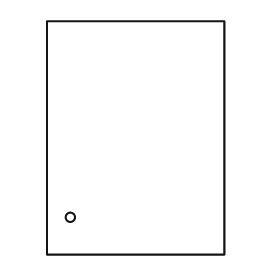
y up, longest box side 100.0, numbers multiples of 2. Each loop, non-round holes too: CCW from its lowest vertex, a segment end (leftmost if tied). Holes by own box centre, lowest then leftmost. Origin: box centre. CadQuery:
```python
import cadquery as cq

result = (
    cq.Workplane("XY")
    .moveTo(-38.0, -50.0)
    .lineTo(38.0, -50.0)
    .lineTo(38.0, 50.0)
    .lineTo(-38.0, 50.0)
    .close()
    .moveTo(-28.0, -34.0)
    .circle(2.0)
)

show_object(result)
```